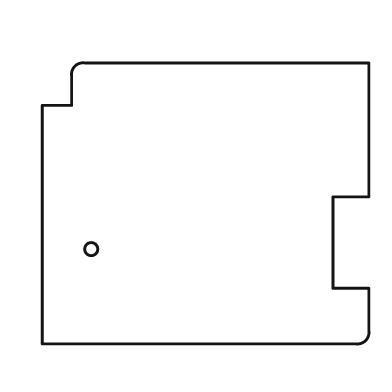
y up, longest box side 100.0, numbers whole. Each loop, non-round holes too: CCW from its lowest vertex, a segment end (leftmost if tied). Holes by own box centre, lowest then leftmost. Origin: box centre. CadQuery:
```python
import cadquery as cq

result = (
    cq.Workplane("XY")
    .moveTo(-50.0, -43.0)
    .lineTo(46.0, -43.0)
    .threePointArc((49.0, -42.0), (50.0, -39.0))
    .lineTo(50.0, -26.0)
    .lineTo(39.0, -26.0)
    .lineTo(39.0, 2.0)
    .lineTo(50.0, 2.0)
    .lineTo(50.0, 43.0)
    .lineTo(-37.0, 43.0)
    .threePointArc((-40.0, 42.0), (-41.0, 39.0))
    .lineTo(-41.0, 30.0)
    .lineTo(-50.0, 30.0)
    .close()
    .moveTo(-35.0, -14.0)
    .circle(2.0)
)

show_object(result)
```